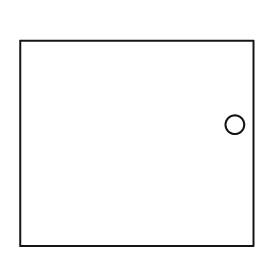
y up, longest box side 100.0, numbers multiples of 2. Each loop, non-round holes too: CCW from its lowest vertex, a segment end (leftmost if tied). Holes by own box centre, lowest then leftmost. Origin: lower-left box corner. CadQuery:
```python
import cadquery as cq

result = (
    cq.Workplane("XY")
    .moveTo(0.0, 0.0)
    .lineTo(100.0, 0.0)
    .lineTo(100.0, 88.0)
    .lineTo(0.0, 88.0)
    .close()
    .moveTo(92.0, 52.0)
    .circle(4.0)
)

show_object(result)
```